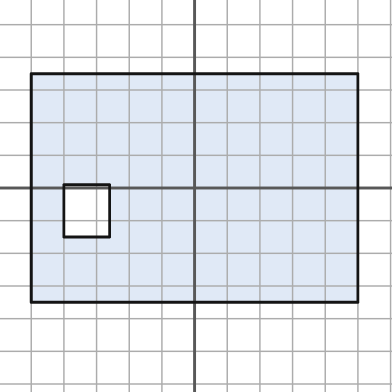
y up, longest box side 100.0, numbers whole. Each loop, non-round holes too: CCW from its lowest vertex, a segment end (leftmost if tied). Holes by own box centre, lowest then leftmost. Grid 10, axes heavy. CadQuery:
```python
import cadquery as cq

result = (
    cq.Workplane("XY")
    .moveTo(-50.0, -35.0)
    .lineTo(50.0, -35.0)
    .lineTo(50.0, 35.0)
    .lineTo(-50.0, 35.0)
    .close()
    .moveTo(-40.0, -15.0)
    .lineTo(-26.0, -15.0)
    .lineTo(-26.0, 1.0)
    .lineTo(-40.0, 1.0)
    .close()
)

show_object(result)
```